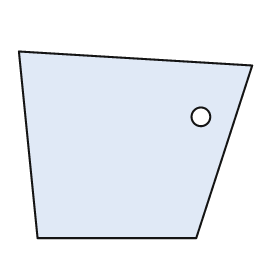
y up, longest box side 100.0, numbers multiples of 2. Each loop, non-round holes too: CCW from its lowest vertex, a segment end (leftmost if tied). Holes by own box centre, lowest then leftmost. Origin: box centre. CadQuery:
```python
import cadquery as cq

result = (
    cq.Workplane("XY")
    .moveTo(-42.0, -40.0)
    .lineTo(26.0, -40.0)
    .lineTo(50.0, 34.0)
    .lineTo(-50.0, 40.0)
    .close()
    .moveTo(28.0, 12.0)
    .circle(4.0)
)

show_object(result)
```